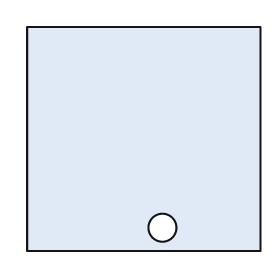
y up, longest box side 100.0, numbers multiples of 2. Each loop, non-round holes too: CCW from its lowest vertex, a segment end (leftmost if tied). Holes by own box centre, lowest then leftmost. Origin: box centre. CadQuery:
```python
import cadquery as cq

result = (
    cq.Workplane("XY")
    .moveTo(-50.0, -48.0)
    .lineTo(50.0, -48.0)
    .lineTo(50.0, 48.0)
    .lineTo(-50.0, 48.0)
    .close()
    .moveTo(8.0, -38.0)
    .circle(6.0)
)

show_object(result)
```